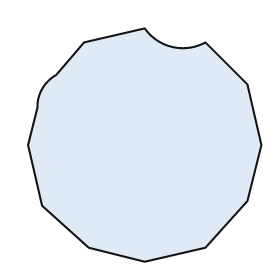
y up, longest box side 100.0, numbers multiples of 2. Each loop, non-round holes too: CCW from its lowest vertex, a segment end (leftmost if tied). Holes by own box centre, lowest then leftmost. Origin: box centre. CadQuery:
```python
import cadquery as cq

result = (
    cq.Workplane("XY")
    .moveTo(0.0, -50.0)
    .lineTo(26.0, -44.0)
    .lineTo(44.0, -24.0)
    .lineTo(50.0, 0.0)
    .lineTo(44.0, 26.0)
    .lineTo(26.0, 44.0)
    .threePointArc((12.0, 42.0), (0.0, 50.0))
    .lineTo(-26.0, 44.0)
    .lineTo(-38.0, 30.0)
    .threePointArc((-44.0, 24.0), (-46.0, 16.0))
    .lineTo(-50.0, 0.0)
    .lineTo(-44.0, -26.0)
    .lineTo(-24.0, -44.0)
    .close()
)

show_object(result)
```